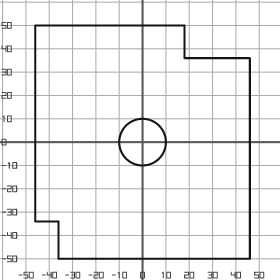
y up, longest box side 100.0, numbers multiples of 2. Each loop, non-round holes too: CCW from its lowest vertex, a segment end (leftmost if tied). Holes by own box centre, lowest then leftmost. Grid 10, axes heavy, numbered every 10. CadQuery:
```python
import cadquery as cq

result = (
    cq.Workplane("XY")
    .moveTo(-36.0, -50.0)
    .lineTo(46.0, -50.0)
    .lineTo(46.0, 36.0)
    .lineTo(18.0, 36.0)
    .lineTo(18.0, 50.0)
    .lineTo(-46.0, 50.0)
    .lineTo(-46.0, -34.0)
    .lineTo(-36.0, -34.0)
    .close()
    .moveTo(0.0, 0.0)
    .circle(10.0)
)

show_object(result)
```